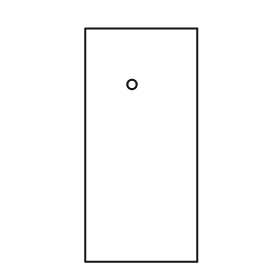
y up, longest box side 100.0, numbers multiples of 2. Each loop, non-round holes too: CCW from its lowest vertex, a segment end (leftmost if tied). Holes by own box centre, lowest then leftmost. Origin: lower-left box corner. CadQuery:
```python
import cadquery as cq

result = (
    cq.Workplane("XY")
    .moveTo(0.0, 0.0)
    .lineTo(48.0, 0.0)
    .lineTo(48.0, 100.0)
    .lineTo(0.0, 100.0)
    .close()
    .moveTo(20.0, 76.0)
    .circle(2.0)
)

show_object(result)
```